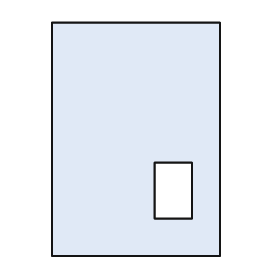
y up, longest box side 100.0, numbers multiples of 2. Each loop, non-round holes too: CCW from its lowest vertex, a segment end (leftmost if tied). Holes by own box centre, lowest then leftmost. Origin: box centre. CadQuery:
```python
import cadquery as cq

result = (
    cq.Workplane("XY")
    .moveTo(-36.0, -50.0)
    .lineTo(36.0, -50.0)
    .lineTo(36.0, 50.0)
    .lineTo(-36.0, 50.0)
    .close()
    .moveTo(8.0, -34.0)
    .lineTo(24.0, -34.0)
    .lineTo(24.0, -10.0)
    .lineTo(8.0, -10.0)
    .close()
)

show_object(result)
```